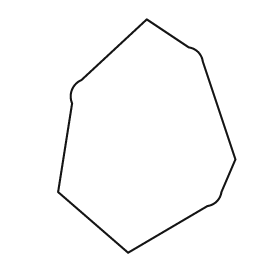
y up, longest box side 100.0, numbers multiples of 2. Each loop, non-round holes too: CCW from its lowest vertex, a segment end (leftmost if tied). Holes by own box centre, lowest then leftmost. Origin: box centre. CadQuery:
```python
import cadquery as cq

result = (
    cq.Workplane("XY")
    .moveTo(-8.0, -50.0)
    .lineTo(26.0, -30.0)
    .threePointArc((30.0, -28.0), (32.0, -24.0))
    .lineTo(38.0, -10.0)
    .lineTo(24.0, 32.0)
    .threePointArc((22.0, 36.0), (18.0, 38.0))
    .lineTo(0.0, 50.0)
    .lineTo(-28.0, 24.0)
    .threePointArc((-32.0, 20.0), (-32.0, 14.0))
    .lineTo(-38.0, -24.0)
    .close()
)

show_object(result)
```